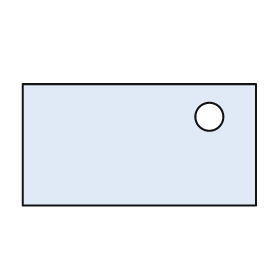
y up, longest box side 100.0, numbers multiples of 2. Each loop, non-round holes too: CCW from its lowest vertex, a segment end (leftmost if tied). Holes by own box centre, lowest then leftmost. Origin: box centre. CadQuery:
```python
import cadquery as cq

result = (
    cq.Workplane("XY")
    .moveTo(-50.0, -26.0)
    .lineTo(50.0, -26.0)
    .lineTo(50.0, 26.0)
    .lineTo(-50.0, 26.0)
    .close()
    .moveTo(30.0, 12.0)
    .circle(6.0)
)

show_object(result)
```